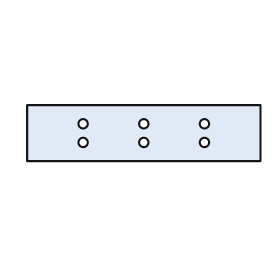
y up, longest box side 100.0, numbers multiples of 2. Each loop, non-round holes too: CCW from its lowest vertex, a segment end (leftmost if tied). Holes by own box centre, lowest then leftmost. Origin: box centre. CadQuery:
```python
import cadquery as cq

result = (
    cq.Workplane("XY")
    .moveTo(-50.0, -12.0)
    .lineTo(50.0, -12.0)
    .lineTo(50.0, 12.0)
    .lineTo(-50.0, 12.0)
    .close()
    .moveTo(-26.0, -4.0)
    .circle(2.0)
    .moveTo(0.0, -4.0)
    .circle(2.0)
    .moveTo(26.0, -4.0)
    .circle(2.0)
    .moveTo(-26.0, 4.0)
    .circle(2.0)
    .moveTo(0.0, 4.0)
    .circle(2.0)
    .moveTo(26.0, 4.0)
    .circle(2.0)
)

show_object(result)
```